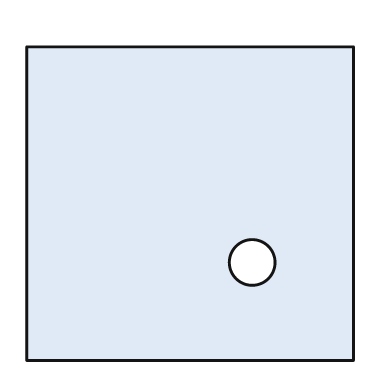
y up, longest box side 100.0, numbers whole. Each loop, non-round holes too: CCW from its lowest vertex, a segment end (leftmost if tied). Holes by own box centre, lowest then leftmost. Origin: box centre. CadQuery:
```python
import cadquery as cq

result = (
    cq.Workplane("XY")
    .moveTo(-50.0, -48.0)
    .lineTo(50.0, -48.0)
    .lineTo(50.0, 48.0)
    .lineTo(-50.0, 48.0)
    .close()
    .moveTo(19.0, -18.0)
    .circle(7.0)
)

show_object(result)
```